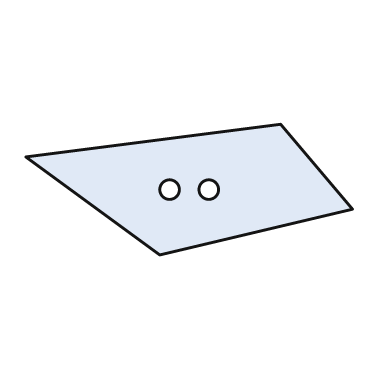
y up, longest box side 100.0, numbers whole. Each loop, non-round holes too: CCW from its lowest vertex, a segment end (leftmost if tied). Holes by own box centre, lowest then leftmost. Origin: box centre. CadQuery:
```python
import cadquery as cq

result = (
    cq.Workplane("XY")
    .moveTo(-9.0, -20.0)
    .lineTo(50.0, -6.0)
    .lineTo(28.0, 20.0)
    .lineTo(-50.0, 10.0)
    .close()
    .moveTo(-6.0, 0.0)
    .circle(3.0)
    .moveTo(6.0, 0.0)
    .circle(3.0)
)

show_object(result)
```